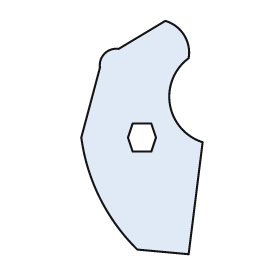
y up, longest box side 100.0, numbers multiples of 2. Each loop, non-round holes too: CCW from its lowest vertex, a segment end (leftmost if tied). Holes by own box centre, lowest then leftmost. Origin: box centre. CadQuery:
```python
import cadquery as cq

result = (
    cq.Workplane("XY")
    .moveTo(20.0, -50.0)
    .lineTo(26.0, -2.0)
    .threePointArc((12.0, 14.0), (20.0, 34.0))
    .threePointArc((18.0, 44.0), (10.0, 50.0))
    .lineTo(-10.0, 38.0)
    .threePointArc((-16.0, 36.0), (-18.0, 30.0))
    .lineTo(-26.0, 0.0)
    .threePointArc((-18.0, -26.0), (-2.0, -48.0))
    .close()
    .moveTo(-4.0, -6.0)
    .lineTo(4.0, -6.0)
    .lineTo(6.0, 0.0)
    .lineTo(4.0, 6.0)
    .lineTo(-4.0, 6.0)
    .lineTo(-6.0, 0.0)
    .close()
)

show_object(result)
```